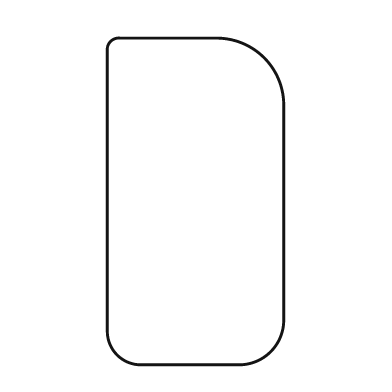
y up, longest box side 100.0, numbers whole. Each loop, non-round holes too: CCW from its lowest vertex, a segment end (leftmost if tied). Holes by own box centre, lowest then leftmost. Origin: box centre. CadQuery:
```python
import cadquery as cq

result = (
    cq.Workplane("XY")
    .moveTo(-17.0, -50.0)
    .lineTo(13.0, -50.0)
    .threePointArc((23.0, -46.0), (27.0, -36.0))
    .lineTo(27.0, 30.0)
    .threePointArc((21.0, 44.0), (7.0, 50.0))
    .lineTo(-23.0, 50.0)
    .threePointArc((-26.0, 49.0), (-27.0, 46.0))
    .lineTo(-27.0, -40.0)
    .threePointArc((-24.0, -47.0), (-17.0, -50.0))
    .close()
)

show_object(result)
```